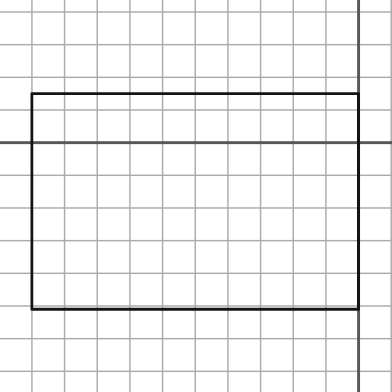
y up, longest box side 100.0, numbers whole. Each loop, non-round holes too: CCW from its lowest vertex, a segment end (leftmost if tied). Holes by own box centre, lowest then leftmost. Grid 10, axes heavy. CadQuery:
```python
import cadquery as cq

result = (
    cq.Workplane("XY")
    .moveTo(-100.0, -51.0)
    .lineTo(0.0, -51.0)
    .lineTo(0.0, 15.0)
    .lineTo(-100.0, 15.0)
    .close()
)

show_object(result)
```